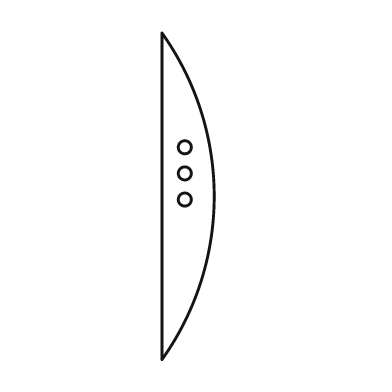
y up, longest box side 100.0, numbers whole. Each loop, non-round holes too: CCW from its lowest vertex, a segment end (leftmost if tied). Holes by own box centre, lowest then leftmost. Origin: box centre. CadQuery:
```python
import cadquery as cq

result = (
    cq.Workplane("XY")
    .moveTo(-8.0, -50.0)
    .threePointArc((8.0, 0.0), (-8.0, 50.0))
    .close()
    .moveTo(-1.0, -1.0)
    .circle(2.0)
    .moveTo(-1.0, 7.0)
    .circle(2.0)
    .moveTo(-1.0, 15.0)
    .circle(2.0)
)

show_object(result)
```